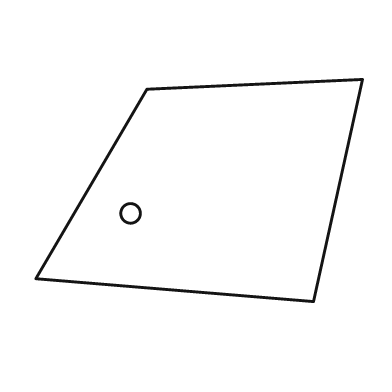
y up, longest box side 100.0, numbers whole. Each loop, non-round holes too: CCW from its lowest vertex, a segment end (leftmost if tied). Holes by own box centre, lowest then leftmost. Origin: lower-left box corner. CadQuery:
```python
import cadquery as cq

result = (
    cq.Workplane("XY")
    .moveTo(85.0, 0.0)
    .lineTo(100.0, 68.0)
    .lineTo(34.0, 65.0)
    .lineTo(0.0, 7.0)
    .close()
    .moveTo(29.0, 27.0)
    .circle(3.0)
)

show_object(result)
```